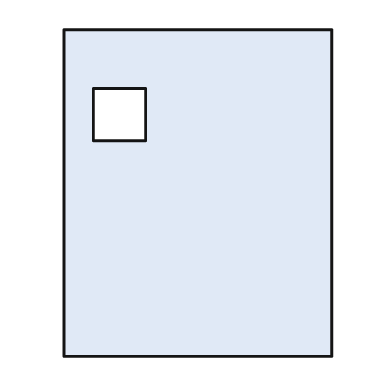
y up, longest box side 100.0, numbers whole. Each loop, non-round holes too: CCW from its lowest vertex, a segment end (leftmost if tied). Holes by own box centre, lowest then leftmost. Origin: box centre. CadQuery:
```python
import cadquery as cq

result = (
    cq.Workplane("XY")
    .moveTo(-41.0, -50.0)
    .lineTo(41.0, -50.0)
    .lineTo(41.0, 50.0)
    .lineTo(-41.0, 50.0)
    .close()
    .moveTo(-32.0, 16.0)
    .lineTo(-16.0, 16.0)
    .lineTo(-16.0, 32.0)
    .lineTo(-32.0, 32.0)
    .close()
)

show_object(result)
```